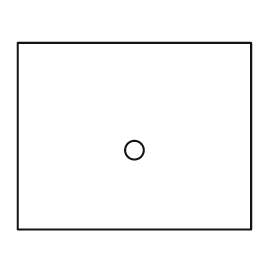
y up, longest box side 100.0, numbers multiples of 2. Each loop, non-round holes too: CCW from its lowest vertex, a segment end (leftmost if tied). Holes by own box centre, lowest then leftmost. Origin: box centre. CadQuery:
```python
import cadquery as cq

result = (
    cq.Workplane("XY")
    .moveTo(-50.0, -40.0)
    .lineTo(50.0, -40.0)
    .lineTo(50.0, 40.0)
    .lineTo(-50.0, 40.0)
    .close()
    .moveTo(0.0, -6.0)
    .circle(4.0)
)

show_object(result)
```